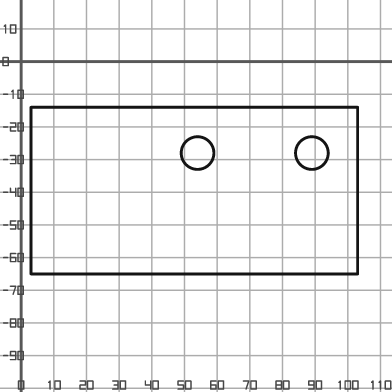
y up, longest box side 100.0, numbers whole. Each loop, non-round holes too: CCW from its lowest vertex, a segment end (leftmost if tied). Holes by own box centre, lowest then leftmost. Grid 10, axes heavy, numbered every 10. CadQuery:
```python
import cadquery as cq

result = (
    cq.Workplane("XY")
    .moveTo(3.0, -65.0)
    .lineTo(103.0, -65.0)
    .lineTo(103.0, -14.0)
    .lineTo(3.0, -14.0)
    .close()
    .moveTo(54.0, -28.0)
    .circle(5.0)
    .moveTo(89.0, -28.0)
    .circle(5.0)
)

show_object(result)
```